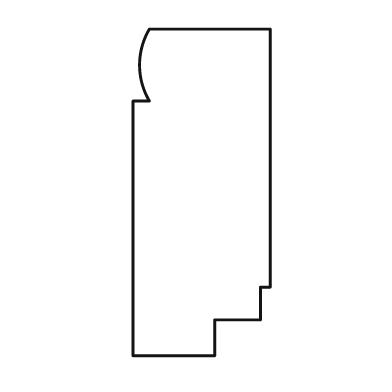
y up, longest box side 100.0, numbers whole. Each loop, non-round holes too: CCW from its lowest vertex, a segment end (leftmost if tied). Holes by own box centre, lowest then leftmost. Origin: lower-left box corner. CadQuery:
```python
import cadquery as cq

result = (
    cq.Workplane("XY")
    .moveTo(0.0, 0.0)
    .lineTo(25.0, 0.0)
    .lineTo(25.0, 11.0)
    .lineTo(39.0, 11.0)
    .lineTo(39.0, 21.0)
    .lineTo(42.0, 21.0)
    .lineTo(42.0, 100.0)
    .lineTo(5.0, 100.0)
    .threePointArc((2.0, 89.0), (5.0, 78.0))
    .lineTo(0.0, 78.0)
    .close()
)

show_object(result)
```